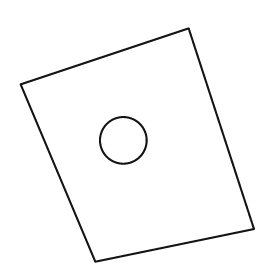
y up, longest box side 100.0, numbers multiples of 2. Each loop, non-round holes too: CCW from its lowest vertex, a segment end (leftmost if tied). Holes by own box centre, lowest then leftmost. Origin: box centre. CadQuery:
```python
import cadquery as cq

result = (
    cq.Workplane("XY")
    .moveTo(-18.0, -50.0)
    .lineTo(50.0, -36.0)
    .lineTo(22.0, 50.0)
    .lineTo(-50.0, 26.0)
    .close()
    .moveTo(-6.0, 2.0)
    .circle(10.0)
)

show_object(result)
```